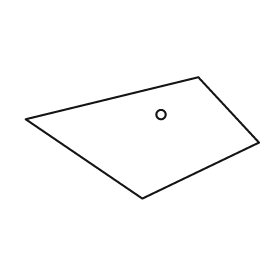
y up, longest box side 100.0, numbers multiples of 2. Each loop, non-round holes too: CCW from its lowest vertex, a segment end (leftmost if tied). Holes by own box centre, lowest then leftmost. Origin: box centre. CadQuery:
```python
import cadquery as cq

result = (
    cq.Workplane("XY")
    .moveTo(0.0, -26.0)
    .lineTo(50.0, -2.0)
    .lineTo(24.0, 26.0)
    .lineTo(-50.0, 8.0)
    .close()
    .moveTo(8.0, 10.0)
    .circle(2.0)
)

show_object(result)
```